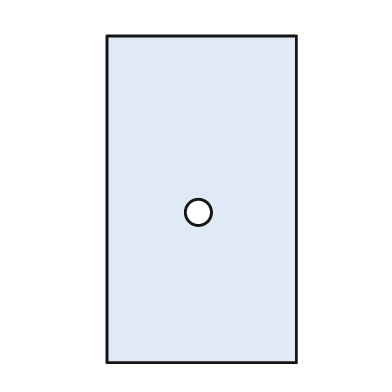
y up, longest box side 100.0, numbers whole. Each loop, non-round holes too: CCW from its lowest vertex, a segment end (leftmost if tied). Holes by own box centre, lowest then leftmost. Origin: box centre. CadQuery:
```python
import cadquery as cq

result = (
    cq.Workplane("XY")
    .moveTo(-29.0, -50.0)
    .lineTo(29.0, -50.0)
    .lineTo(29.0, 50.0)
    .lineTo(-29.0, 50.0)
    .close()
    .moveTo(-1.0, -4.0)
    .circle(4.0)
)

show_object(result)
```